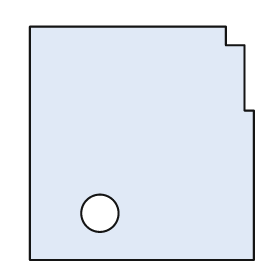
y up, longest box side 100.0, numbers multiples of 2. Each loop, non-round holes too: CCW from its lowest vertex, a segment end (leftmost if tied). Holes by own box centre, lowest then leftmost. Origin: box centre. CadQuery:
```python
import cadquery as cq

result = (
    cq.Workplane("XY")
    .moveTo(-48.0, -50.0)
    .lineTo(48.0, -50.0)
    .lineTo(48.0, 14.0)
    .lineTo(44.0, 14.0)
    .lineTo(44.0, 42.0)
    .lineTo(36.0, 42.0)
    .lineTo(36.0, 50.0)
    .lineTo(-48.0, 50.0)
    .close()
    .moveTo(-18.0, -30.0)
    .circle(8.0)
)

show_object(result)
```